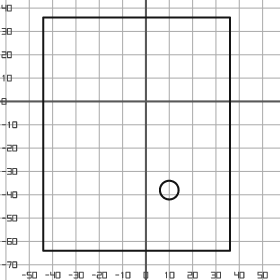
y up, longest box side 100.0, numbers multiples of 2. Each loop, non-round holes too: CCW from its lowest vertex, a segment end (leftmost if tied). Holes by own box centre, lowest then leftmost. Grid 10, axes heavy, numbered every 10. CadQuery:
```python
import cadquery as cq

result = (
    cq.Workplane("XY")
    .moveTo(-44.0, -64.0)
    .lineTo(36.0, -64.0)
    .lineTo(36.0, 36.0)
    .lineTo(-44.0, 36.0)
    .close()
    .moveTo(10.0, -38.0)
    .circle(4.0)
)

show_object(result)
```